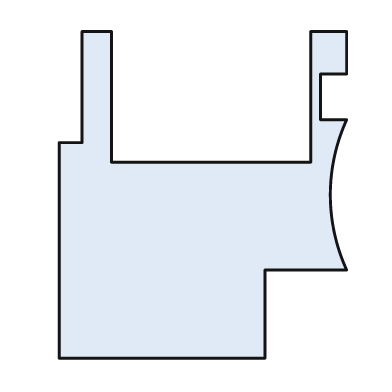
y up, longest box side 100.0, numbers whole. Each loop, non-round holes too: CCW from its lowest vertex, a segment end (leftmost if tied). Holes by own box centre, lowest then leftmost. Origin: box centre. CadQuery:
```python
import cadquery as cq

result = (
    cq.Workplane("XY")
    .moveTo(-44.0, -50.0)
    .lineTo(19.0, -50.0)
    .lineTo(19.0, -23.0)
    .lineTo(44.0, -23.0)
    .threePointArc((39.0, 0.0), (44.0, 23.0))
    .lineTo(36.0, 23.0)
    .lineTo(36.0, 37.0)
    .lineTo(44.0, 37.0)
    .lineTo(44.0, 50.0)
    .lineTo(33.0, 50.0)
    .lineTo(33.0, 10.0)
    .lineTo(-28.0, 10.0)
    .lineTo(-28.0, 50.0)
    .lineTo(-37.0, 50.0)
    .lineTo(-37.0, 16.0)
    .lineTo(-44.0, 16.0)
    .close()
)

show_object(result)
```